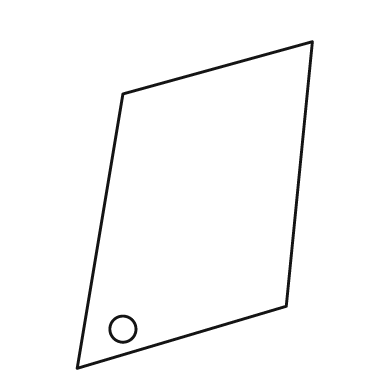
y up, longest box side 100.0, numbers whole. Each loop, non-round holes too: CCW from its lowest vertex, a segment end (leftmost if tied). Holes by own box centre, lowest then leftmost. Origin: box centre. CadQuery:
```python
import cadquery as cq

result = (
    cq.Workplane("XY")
    .moveTo(-36.0, -50.0)
    .lineTo(28.0, -31.0)
    .lineTo(36.0, 50.0)
    .lineTo(-22.0, 34.0)
    .close()
    .moveTo(-22.0, -38.0)
    .circle(4.0)
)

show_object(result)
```